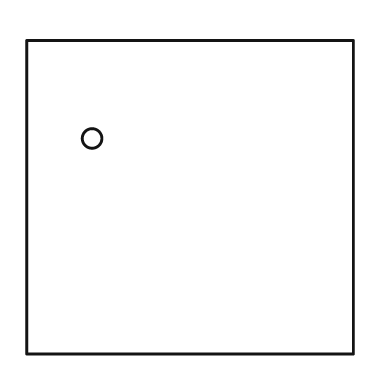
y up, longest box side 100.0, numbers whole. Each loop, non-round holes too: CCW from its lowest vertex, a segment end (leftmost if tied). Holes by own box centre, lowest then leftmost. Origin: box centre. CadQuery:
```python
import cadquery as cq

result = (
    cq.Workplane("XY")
    .moveTo(-50.0, -48.0)
    .lineTo(50.0, -48.0)
    .lineTo(50.0, 48.0)
    .lineTo(-50.0, 48.0)
    .close()
    .moveTo(-30.0, 18.0)
    .circle(3.0)
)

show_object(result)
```